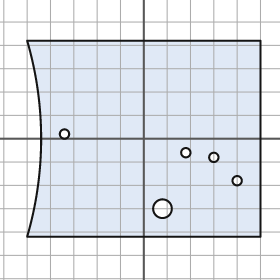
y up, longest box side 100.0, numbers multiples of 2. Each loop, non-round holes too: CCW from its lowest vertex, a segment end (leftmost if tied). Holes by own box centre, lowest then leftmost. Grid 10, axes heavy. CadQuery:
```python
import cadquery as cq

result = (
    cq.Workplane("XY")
    .moveTo(-50.0, -42.0)
    .lineTo(50.0, -42.0)
    .lineTo(50.0, 42.0)
    .lineTo(-50.0, 42.0)
    .threePointArc((-44.0, 0.0), (-50.0, -42.0))
    .close()
    .moveTo(8.0, -30.0)
    .circle(4.0)
    .moveTo(40.0, -18.0)
    .circle(2.0)
    .moveTo(30.0, -8.0)
    .circle(2.0)
    .moveTo(18.0, -6.0)
    .circle(2.0)
    .moveTo(-34.0, 2.0)
    .circle(2.0)
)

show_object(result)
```